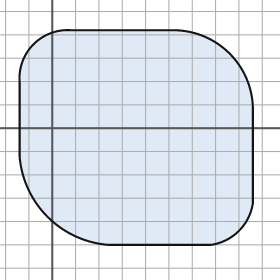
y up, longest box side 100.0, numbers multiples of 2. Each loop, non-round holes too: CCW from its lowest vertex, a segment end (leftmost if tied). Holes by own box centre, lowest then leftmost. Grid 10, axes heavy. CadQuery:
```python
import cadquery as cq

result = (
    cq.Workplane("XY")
    .moveTo(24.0, -50.0)
    .lineTo(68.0, -50.0)
    .threePointArc((80.0, -44.0), (86.0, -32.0))
    .lineTo(86.0, 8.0)
    .threePointArc((76.0, 32.0), (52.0, 42.0))
    .lineTo(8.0, 42.0)
    .threePointArc((-8.0, 36.0), (-14.0, 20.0))
    .lineTo(-14.0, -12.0)
    .threePointArc((-2.0, -38.0), (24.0, -50.0))
    .close()
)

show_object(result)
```